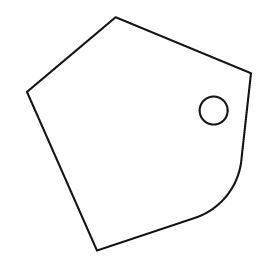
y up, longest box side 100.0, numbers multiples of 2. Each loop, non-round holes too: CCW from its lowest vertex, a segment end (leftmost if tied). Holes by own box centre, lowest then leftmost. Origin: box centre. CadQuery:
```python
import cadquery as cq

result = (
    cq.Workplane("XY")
    .moveTo(-18.0, -50.0)
    .lineTo(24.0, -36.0)
    .threePointArc((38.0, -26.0), (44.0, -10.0))
    .lineTo(48.0, 26.0)
    .lineTo(-10.0, 50.0)
    .lineTo(-48.0, 18.0)
    .close()
    .moveTo(32.0, 10.0)
    .circle(6.0)
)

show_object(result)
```